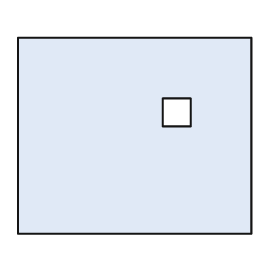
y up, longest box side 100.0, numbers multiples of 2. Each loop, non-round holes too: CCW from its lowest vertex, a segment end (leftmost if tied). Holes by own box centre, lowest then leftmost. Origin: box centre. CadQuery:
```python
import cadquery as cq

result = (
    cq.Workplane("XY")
    .moveTo(-50.0, -42.0)
    .lineTo(50.0, -42.0)
    .lineTo(50.0, 42.0)
    .lineTo(-50.0, 42.0)
    .close()
    .moveTo(12.0, 4.0)
    .lineTo(24.0, 4.0)
    .lineTo(24.0, 16.0)
    .lineTo(12.0, 16.0)
    .close()
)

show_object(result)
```